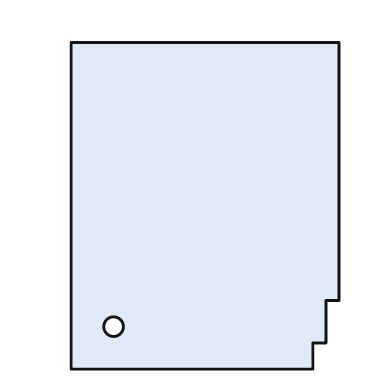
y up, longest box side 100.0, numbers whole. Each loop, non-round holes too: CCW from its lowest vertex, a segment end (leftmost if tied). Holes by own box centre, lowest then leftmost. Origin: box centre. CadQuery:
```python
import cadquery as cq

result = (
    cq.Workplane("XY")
    .moveTo(-41.0, -50.0)
    .lineTo(33.0, -50.0)
    .lineTo(33.0, -42.0)
    .lineTo(37.0, -42.0)
    .lineTo(37.0, -29.0)
    .lineTo(41.0, -29.0)
    .lineTo(41.0, 50.0)
    .lineTo(-41.0, 50.0)
    .close()
    .moveTo(-28.0, -37.0)
    .circle(3.0)
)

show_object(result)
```